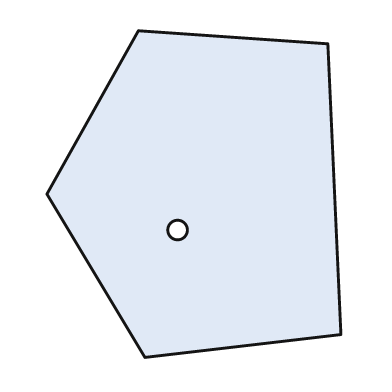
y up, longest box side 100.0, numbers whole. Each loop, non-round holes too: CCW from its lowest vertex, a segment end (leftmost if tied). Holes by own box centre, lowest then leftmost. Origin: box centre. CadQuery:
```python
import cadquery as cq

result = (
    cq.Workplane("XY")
    .moveTo(-15.0, -50.0)
    .lineTo(45.0, -43.0)
    .lineTo(41.0, 46.0)
    .lineTo(-17.0, 50.0)
    .lineTo(-45.0, 0.0)
    .close()
    .moveTo(-5.0, -11.0)
    .circle(3.0)
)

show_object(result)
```